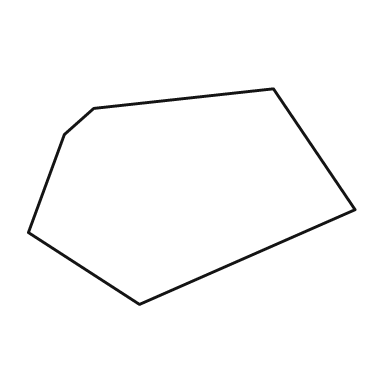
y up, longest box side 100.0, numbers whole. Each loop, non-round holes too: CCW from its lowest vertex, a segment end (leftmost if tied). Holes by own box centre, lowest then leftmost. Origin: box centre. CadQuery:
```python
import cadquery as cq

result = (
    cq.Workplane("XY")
    .moveTo(-16.0, -33.0)
    .lineTo(50.0, -4.0)
    .lineTo(25.0, 33.0)
    .lineTo(-30.0, 27.0)
    .lineTo(-39.0, 19.0)
    .lineTo(-50.0, -11.0)
    .close()
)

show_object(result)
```